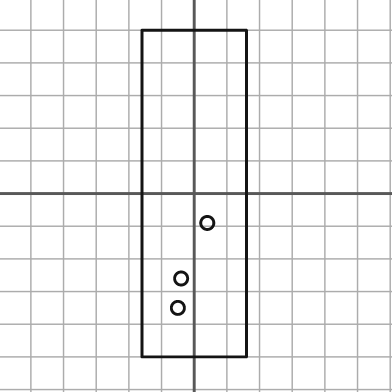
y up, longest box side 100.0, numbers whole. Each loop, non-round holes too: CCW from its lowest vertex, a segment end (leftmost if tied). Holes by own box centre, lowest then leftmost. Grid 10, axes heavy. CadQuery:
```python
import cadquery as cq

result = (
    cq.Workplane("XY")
    .moveTo(-16.0, -50.0)
    .lineTo(16.0, -50.0)
    .lineTo(16.0, 50.0)
    .lineTo(-16.0, 50.0)
    .close()
    .moveTo(-5.0, -35.0)
    .circle(2.0)
    .moveTo(-4.0, -26.0)
    .circle(2.0)
    .moveTo(4.0, -9.0)
    .circle(2.0)
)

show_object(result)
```